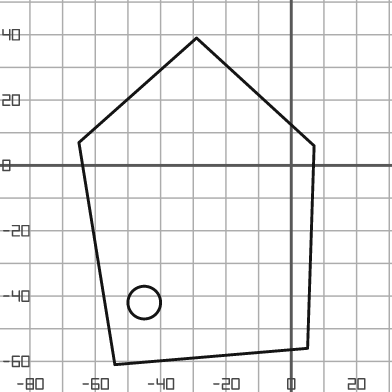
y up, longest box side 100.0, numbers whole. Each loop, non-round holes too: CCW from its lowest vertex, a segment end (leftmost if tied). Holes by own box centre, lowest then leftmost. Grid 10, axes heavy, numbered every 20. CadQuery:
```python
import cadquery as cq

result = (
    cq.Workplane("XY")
    .moveTo(-54.0, -61.0)
    .lineTo(5.0, -56.0)
    .lineTo(7.0, 6.0)
    .lineTo(-29.0, 39.0)
    .lineTo(-65.0, 7.0)
    .close()
    .moveTo(-45.0, -42.0)
    .circle(5.0)
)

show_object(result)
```